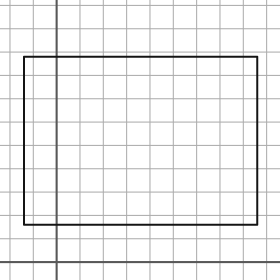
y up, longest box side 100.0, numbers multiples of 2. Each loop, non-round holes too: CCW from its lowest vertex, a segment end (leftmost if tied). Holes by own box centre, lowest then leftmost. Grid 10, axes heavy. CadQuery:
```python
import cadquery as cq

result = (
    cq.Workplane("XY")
    .moveTo(-14.0, 16.0)
    .lineTo(86.0, 16.0)
    .lineTo(86.0, 88.0)
    .lineTo(-14.0, 88.0)
    .close()
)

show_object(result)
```